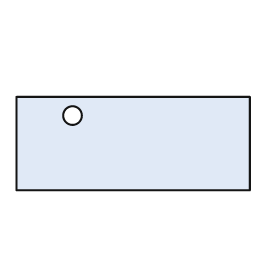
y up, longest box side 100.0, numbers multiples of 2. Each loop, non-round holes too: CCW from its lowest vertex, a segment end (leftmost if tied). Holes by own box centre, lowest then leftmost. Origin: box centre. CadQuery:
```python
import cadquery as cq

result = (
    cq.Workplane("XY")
    .moveTo(-50.0, -20.0)
    .lineTo(50.0, -20.0)
    .lineTo(50.0, 20.0)
    .lineTo(-50.0, 20.0)
    .close()
    .moveTo(-26.0, 12.0)
    .circle(4.0)
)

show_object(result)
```